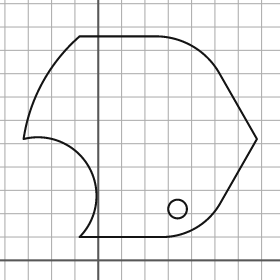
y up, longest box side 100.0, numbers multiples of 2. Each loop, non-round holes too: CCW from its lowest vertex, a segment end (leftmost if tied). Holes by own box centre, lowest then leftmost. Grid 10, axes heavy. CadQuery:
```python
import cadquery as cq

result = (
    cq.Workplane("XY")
    .moveTo(-8.0, 10.0)
    .lineTo(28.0, 10.0)
    .threePointArc((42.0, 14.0), (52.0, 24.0))
    .lineTo(68.0, 52.0)
    .lineTo(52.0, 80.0)
    .threePointArc((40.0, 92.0), (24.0, 96.0))
    .lineTo(-8.0, 96.0)
    .threePointArc((-24.0, 76.0), (-32.0, 52.0))
    .threePointArc((-4.0, 40.0), (-8.0, 10.0))
    .close()
    .moveTo(34.0, 22.0)
    .circle(4.0)
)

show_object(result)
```